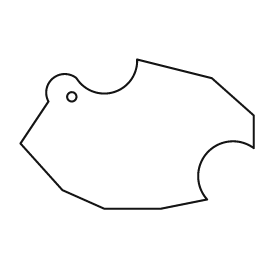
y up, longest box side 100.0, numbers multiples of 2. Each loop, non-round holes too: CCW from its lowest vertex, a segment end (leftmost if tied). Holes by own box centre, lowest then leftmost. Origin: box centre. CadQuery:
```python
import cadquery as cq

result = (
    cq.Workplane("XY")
    .moveTo(-14.0, -32.0)
    .lineTo(10.0, -32.0)
    .lineTo(30.0, -28.0)
    .threePointArc((30.0, -8.0), (50.0, -6.0))
    .lineTo(50.0, 8.0)
    .lineTo(32.0, 24.0)
    .lineTo(0.0, 32.0)
    .threePointArc((-10.0, 18.0), (-26.0, 24.0))
    .threePointArc((-36.0, 24.0), (-38.0, 14.0))
    .lineTo(-50.0, -4.0)
    .lineTo(-32.0, -24.0)
    .close()
    .moveTo(-28.0, 16.0)
    .circle(2.0)
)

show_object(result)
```